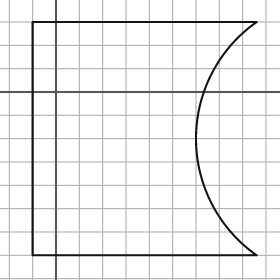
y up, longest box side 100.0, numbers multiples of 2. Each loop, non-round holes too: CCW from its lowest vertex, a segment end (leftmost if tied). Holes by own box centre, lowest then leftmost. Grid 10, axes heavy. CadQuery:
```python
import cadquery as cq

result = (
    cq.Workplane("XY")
    .moveTo(-10.0, -70.0)
    .lineTo(86.0, -70.0)
    .threePointArc((60.0, -20.0), (86.0, 30.0))
    .lineTo(-10.0, 30.0)
    .close()
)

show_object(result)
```